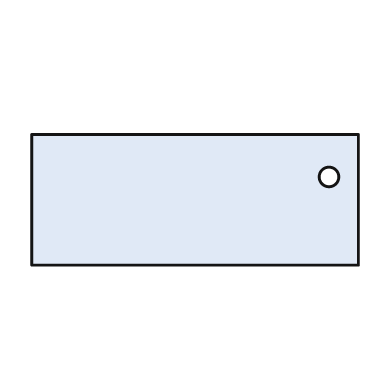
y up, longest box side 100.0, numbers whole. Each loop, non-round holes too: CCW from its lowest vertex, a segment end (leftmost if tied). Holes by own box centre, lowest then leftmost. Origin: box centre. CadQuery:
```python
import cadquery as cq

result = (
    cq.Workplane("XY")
    .moveTo(-50.0, -20.0)
    .lineTo(50.0, -20.0)
    .lineTo(50.0, 20.0)
    .lineTo(-50.0, 20.0)
    .close()
    .moveTo(41.0, 7.0)
    .circle(3.0)
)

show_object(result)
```